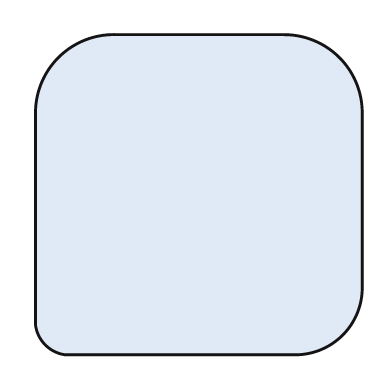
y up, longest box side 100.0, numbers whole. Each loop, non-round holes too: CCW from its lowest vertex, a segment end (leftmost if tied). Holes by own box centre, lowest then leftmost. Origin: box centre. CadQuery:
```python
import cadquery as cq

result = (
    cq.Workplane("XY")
    .moveTo(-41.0, -49.0)
    .lineTo(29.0, -49.0)
    .threePointArc((44.0, -43.0), (50.0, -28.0))
    .lineTo(50.0, 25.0)
    .threePointArc((43.0, 42.0), (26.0, 49.0))
    .lineTo(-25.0, 49.0)
    .threePointArc((-43.0, 42.0), (-50.0, 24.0))
    .lineTo(-50.0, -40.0)
    .threePointArc((-47.0, -46.0), (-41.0, -49.0))
    .close()
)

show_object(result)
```